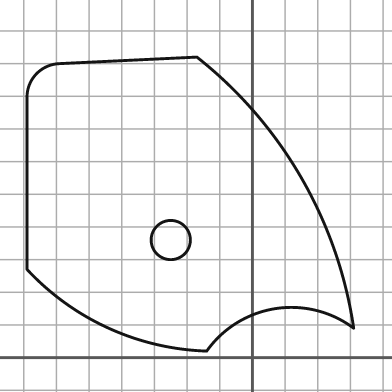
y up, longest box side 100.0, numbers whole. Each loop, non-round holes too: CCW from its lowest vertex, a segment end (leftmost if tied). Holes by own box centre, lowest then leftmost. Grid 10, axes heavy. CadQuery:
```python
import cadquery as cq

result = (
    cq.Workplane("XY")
    .moveTo(-14.0, 2.0)
    .threePointArc((7.0, 15.0), (31.0, 9.0))
    .threePointArc((15.0, 55.0), (-17.0, 92.0))
    .lineTo(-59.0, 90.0)
    .threePointArc((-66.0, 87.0), (-69.0, 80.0))
    .lineTo(-69.0, 27.0)
    .threePointArc((-44.0, 9.0), (-14.0, 2.0))
    .close()
    .moveTo(-25.0, 36.0)
    .circle(6.0)
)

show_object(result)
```